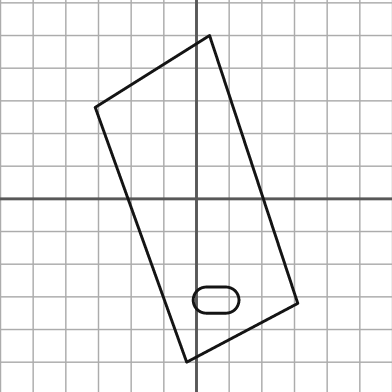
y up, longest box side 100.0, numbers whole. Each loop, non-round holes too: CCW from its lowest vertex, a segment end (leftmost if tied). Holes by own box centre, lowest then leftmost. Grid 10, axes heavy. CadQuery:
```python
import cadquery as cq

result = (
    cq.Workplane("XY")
    .moveTo(-3.0, -50.0)
    .lineTo(31.0, -32.0)
    .lineTo(4.0, 50.0)
    .lineTo(-31.0, 28.0)
    .close()
    .moveTo(3.0, -35.0)
    .lineTo(9.0, -35.0)
    .threePointArc((13.0, -31.0), (9.0, -27.0))
    .lineTo(3.0, -27.0)
    .threePointArc((-1.0, -31.0), (3.0, -35.0))
    .close()
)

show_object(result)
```